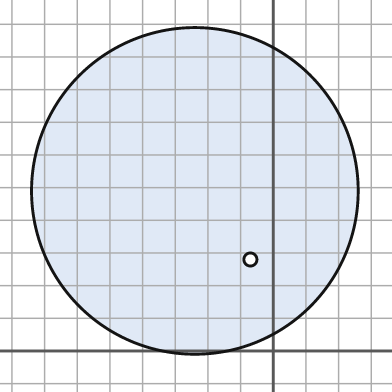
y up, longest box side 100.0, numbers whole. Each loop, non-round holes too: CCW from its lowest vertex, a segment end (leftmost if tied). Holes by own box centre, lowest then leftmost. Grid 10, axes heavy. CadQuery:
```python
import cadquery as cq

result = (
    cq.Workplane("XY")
    .moveTo(-24.0, 49.0)
    .circle(50.0)
    .moveTo(-7.0, 28.0)
    .circle(2.0)
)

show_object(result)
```